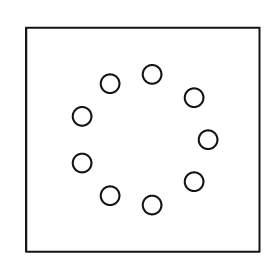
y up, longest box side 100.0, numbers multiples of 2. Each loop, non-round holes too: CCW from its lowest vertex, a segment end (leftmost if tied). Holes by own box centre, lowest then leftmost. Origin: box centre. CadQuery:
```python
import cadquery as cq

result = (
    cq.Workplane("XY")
    .moveTo(-50.0, -48.0)
    .lineTo(50.0, -48.0)
    .lineTo(50.0, 48.0)
    .lineTo(-50.0, 48.0)
    .close()
    .moveTo(4.0, -28.0)
    .circle(4.0)
    .moveTo(-14.0, -24.0)
    .circle(4.0)
    .moveTo(22.0, -18.0)
    .circle(4.0)
    .moveTo(-26.0, -10.0)
    .circle(4.0)
    .moveTo(28.0, 0.0)
    .circle(4.0)
    .moveTo(-26.0, 10.0)
    .circle(4.0)
    .moveTo(22.0, 18.0)
    .circle(4.0)
    .moveTo(-14.0, 24.0)
    .circle(4.0)
    .moveTo(4.0, 28.0)
    .circle(4.0)
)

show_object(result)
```